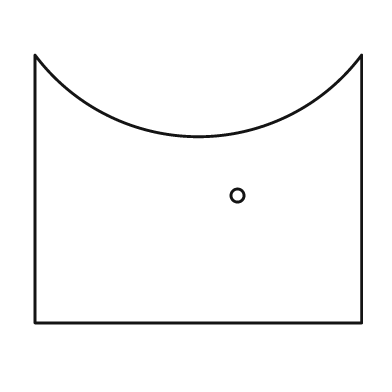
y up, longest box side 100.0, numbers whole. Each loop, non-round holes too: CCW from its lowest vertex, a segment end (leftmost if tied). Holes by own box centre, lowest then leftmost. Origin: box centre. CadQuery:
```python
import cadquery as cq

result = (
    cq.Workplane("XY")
    .moveTo(-50.0, -41.0)
    .lineTo(50.0, -41.0)
    .lineTo(50.0, 41.0)
    .threePointArc((0.0, 16.0), (-50.0, 41.0))
    .close()
    .moveTo(12.0, -2.0)
    .circle(2.0)
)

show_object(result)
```